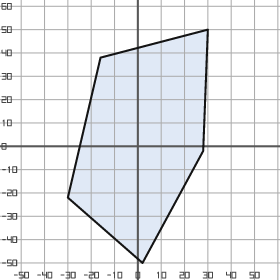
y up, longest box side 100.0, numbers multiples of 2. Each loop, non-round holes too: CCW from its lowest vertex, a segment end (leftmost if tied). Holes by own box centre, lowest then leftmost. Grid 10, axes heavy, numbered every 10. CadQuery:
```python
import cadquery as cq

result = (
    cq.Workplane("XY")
    .moveTo(2.0, -50.0)
    .lineTo(28.0, -2.0)
    .lineTo(30.0, 50.0)
    .lineTo(-16.0, 38.0)
    .lineTo(-30.0, -22.0)
    .close()
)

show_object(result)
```